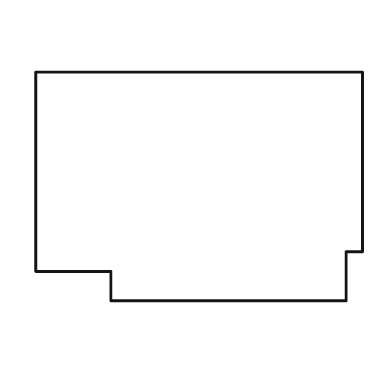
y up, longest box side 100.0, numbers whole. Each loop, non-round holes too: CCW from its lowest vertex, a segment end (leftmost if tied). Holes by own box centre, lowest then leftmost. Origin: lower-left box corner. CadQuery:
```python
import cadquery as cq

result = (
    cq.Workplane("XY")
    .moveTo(23.0, 0.0)
    .lineTo(95.0, 0.0)
    .lineTo(95.0, 15.0)
    .lineTo(100.0, 15.0)
    .lineTo(100.0, 70.0)
    .lineTo(0.0, 70.0)
    .lineTo(0.0, 9.0)
    .lineTo(23.0, 9.0)
    .close()
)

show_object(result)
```